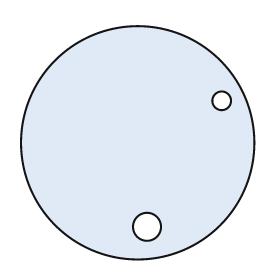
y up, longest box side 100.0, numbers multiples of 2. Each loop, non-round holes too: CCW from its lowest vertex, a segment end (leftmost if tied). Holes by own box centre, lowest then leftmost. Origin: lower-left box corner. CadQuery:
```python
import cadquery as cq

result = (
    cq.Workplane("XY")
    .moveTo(50.0, 50.0)
    .circle(50.0)
    .moveTo(54.0, 14.0)
    .circle(6.0)
    .moveTo(86.0, 68.0)
    .circle(4.0)
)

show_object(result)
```